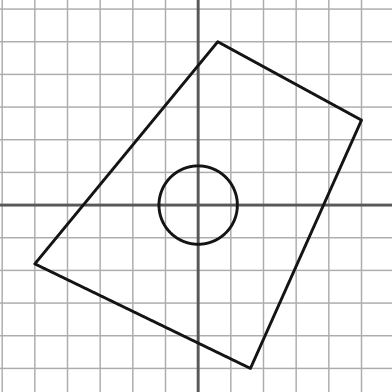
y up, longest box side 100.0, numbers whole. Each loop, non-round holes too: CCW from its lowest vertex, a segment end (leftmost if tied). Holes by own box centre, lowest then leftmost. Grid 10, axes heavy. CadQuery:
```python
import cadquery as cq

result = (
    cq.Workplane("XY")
    .moveTo(16.0, -50.0)
    .lineTo(50.0, 26.0)
    .lineTo(6.0, 50.0)
    .lineTo(-50.0, -18.0)
    .close()
    .moveTo(0.0, 0.0)
    .circle(12.0)
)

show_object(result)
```